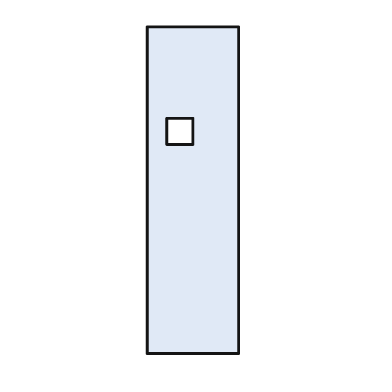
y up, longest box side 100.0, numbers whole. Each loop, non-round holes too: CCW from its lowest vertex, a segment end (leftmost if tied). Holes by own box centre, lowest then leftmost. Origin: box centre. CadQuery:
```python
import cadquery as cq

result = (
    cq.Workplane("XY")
    .moveTo(-14.0, -50.0)
    .lineTo(14.0, -50.0)
    .lineTo(14.0, 50.0)
    .lineTo(-14.0, 50.0)
    .close()
    .moveTo(-8.0, 14.0)
    .lineTo(0.0, 14.0)
    .lineTo(0.0, 22.0)
    .lineTo(-8.0, 22.0)
    .close()
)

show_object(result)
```